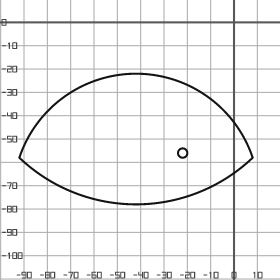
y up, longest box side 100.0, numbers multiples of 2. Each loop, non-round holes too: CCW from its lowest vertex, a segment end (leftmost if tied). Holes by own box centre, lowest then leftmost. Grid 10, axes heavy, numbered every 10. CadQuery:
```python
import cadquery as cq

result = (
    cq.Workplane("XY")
    .moveTo(-92.0, -58.0)
    .threePointArc((-42.0, -78.0), (8.0, -58.0))
    .threePointArc((-42.0, -22.0), (-92.0, -58.0))
    .close()
    .moveTo(-22.0, -56.0)
    .circle(2.0)
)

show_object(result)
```